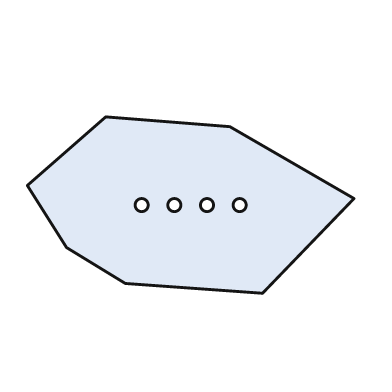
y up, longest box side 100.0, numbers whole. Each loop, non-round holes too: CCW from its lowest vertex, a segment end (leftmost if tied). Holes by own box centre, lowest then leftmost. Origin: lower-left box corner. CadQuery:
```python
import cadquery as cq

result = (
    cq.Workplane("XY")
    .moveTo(72.0, 0.0)
    .lineTo(100.0, 29.0)
    .lineTo(62.0, 51.0)
    .lineTo(24.0, 54.0)
    .lineTo(0.0, 33.0)
    .lineTo(12.0, 14.0)
    .lineTo(30.0, 3.0)
    .close()
    .moveTo(35.0, 27.0)
    .circle(2.0)
    .moveTo(45.0, 27.0)
    .circle(2.0)
    .moveTo(55.0, 27.0)
    .circle(2.0)
    .moveTo(65.0, 27.0)
    .circle(2.0)
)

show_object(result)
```